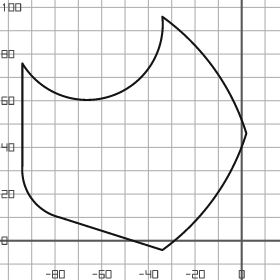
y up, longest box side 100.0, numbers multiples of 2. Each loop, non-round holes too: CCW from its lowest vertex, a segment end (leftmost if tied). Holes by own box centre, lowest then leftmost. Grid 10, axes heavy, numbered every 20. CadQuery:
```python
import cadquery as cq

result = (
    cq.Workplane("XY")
    .moveTo(-34.0, -4.0)
    .threePointArc((-12.0, 18.0), (2.0, 46.0))
    .threePointArc((-12.0, 74.0), (-34.0, 96.0))
    .threePointArc((-56.0, 62.0), (-94.0, 76.0))
    .lineTo(-94.0, 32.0)
    .threePointArc((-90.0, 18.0), (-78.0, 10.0))
    .close()
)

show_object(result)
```